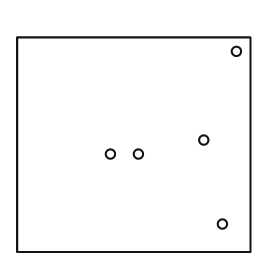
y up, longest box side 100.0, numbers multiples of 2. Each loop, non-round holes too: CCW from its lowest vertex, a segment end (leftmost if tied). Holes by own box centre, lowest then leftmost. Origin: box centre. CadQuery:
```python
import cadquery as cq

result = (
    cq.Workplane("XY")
    .moveTo(-50.0, -46.0)
    .lineTo(50.0, -46.0)
    .lineTo(50.0, 46.0)
    .lineTo(-50.0, 46.0)
    .close()
    .moveTo(38.0, -34.0)
    .circle(2.0)
    .moveTo(-10.0, -4.0)
    .circle(2.0)
    .moveTo(2.0, -4.0)
    .circle(2.0)
    .moveTo(30.0, 2.0)
    .circle(2.0)
    .moveTo(44.0, 40.0)
    .circle(2.0)
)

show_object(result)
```